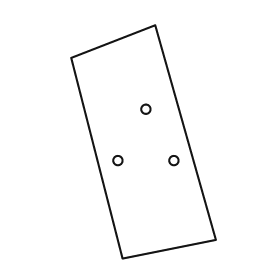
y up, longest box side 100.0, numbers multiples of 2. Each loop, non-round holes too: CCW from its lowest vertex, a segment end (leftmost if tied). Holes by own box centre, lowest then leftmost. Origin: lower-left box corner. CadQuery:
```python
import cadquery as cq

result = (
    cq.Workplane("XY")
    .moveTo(22.0, 0.0)
    .lineTo(62.0, 8.0)
    .lineTo(36.0, 100.0)
    .lineTo(0.0, 86.0)
    .close()
    .moveTo(20.0, 42.0)
    .circle(2.0)
    .moveTo(44.0, 42.0)
    .circle(2.0)
    .moveTo(32.0, 64.0)
    .circle(2.0)
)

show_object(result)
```